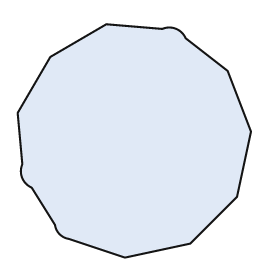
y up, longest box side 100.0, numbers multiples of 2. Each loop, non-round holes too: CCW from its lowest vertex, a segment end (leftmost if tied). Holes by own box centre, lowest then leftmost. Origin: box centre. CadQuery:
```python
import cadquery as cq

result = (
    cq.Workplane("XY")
    .moveTo(-4.0, -50.0)
    .lineTo(24.0, -44.0)
    .lineTo(44.0, -24.0)
    .lineTo(50.0, 4.0)
    .lineTo(40.0, 30.0)
    .lineTo(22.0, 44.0)
    .threePointArc((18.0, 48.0), (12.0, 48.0))
    .lineTo(-12.0, 50.0)
    .lineTo(-36.0, 36.0)
    .lineTo(-50.0, 12.0)
    .lineTo(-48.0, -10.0)
    .threePointArc((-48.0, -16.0), (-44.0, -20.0))
    .lineTo(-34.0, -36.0)
    .threePointArc((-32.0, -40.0), (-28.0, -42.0))
    .close()
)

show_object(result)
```